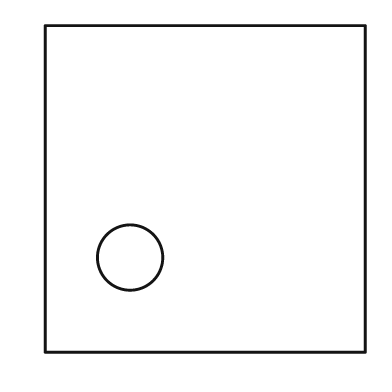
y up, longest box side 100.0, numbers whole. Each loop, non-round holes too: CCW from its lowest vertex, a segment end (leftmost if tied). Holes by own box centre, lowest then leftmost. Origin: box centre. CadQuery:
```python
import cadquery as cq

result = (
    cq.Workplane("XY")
    .moveTo(-49.0, -50.0)
    .lineTo(49.0, -50.0)
    .lineTo(49.0, 50.0)
    .lineTo(-49.0, 50.0)
    .close()
    .moveTo(-23.0, -21.0)
    .circle(10.0)
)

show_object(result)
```